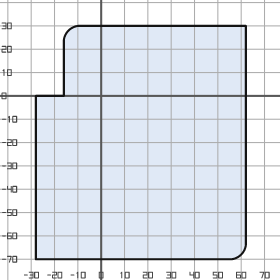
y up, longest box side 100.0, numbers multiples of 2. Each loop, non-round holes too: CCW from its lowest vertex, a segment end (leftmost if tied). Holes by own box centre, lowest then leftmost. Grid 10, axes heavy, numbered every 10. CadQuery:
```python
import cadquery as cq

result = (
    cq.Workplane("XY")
    .moveTo(-28.0, -70.0)
    .lineTo(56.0, -70.0)
    .threePointArc((60.0, -68.0), (62.0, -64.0))
    .lineTo(62.0, 30.0)
    .lineTo(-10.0, 30.0)
    .threePointArc((-14.0, 28.0), (-16.0, 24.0))
    .lineTo(-16.0, 0.0)
    .lineTo(-28.0, 0.0)
    .close()
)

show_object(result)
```